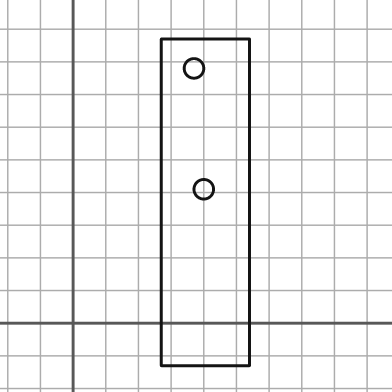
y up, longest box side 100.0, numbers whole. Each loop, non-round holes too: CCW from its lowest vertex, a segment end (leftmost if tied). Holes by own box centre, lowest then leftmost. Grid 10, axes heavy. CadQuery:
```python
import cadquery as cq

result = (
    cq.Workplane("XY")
    .moveTo(27.0, -13.0)
    .lineTo(54.0, -13.0)
    .lineTo(54.0, 87.0)
    .lineTo(27.0, 87.0)
    .close()
    .moveTo(40.0, 41.0)
    .circle(3.0)
    .moveTo(37.0, 78.0)
    .circle(3.0)
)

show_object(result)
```